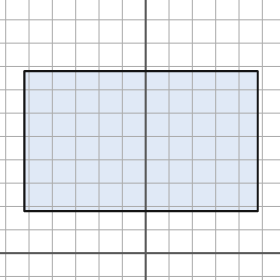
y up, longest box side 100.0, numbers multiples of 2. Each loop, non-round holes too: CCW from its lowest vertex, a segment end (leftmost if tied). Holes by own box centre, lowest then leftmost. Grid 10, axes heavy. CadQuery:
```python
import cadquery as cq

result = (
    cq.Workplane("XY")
    .moveTo(-52.0, 18.0)
    .lineTo(48.0, 18.0)
    .lineTo(48.0, 78.0)
    .lineTo(-52.0, 78.0)
    .close()
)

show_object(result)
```